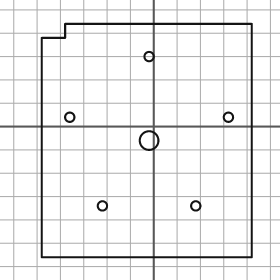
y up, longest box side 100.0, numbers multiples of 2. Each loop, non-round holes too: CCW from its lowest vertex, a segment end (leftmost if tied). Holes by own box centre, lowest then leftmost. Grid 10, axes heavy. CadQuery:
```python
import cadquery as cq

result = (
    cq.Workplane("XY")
    .moveTo(-48.0, -56.0)
    .lineTo(42.0, -56.0)
    .lineTo(42.0, 44.0)
    .lineTo(-38.0, 44.0)
    .lineTo(-38.0, 38.0)
    .lineTo(-48.0, 38.0)
    .close()
    .moveTo(-22.0, -34.0)
    .circle(2.0)
    .moveTo(18.0, -34.0)
    .circle(2.0)
    .moveTo(-2.0, -6.0)
    .circle(4.0)
    .moveTo(-36.0, 4.0)
    .circle(2.0)
    .moveTo(32.0, 4.0)
    .circle(2.0)
    .moveTo(-2.0, 30.0)
    .circle(2.0)
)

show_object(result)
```